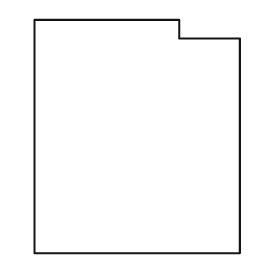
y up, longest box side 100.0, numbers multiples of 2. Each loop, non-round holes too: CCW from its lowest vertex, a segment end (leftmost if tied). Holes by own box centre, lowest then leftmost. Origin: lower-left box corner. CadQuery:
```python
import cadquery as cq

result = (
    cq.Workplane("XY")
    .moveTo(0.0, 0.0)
    .lineTo(88.0, 0.0)
    .lineTo(88.0, 92.0)
    .lineTo(62.0, 92.0)
    .lineTo(62.0, 100.0)
    .lineTo(0.0, 100.0)
    .close()
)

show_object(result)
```